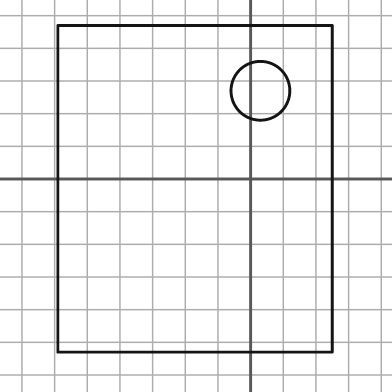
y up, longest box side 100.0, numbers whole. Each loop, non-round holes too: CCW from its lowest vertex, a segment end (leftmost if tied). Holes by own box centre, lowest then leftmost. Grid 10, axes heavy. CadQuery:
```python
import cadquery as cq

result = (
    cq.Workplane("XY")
    .moveTo(-59.0, -53.0)
    .lineTo(25.0, -53.0)
    .lineTo(25.0, 47.0)
    .lineTo(-59.0, 47.0)
    .close()
    .moveTo(3.0, 27.0)
    .circle(9.0)
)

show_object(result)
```